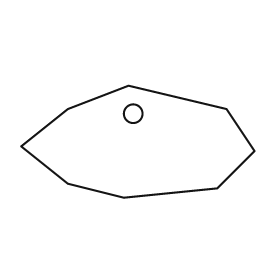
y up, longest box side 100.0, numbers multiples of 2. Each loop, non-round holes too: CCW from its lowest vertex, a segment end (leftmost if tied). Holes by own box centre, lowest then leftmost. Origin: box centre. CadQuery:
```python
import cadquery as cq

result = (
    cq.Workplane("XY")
    .moveTo(-6.0, -24.0)
    .lineTo(34.0, -20.0)
    .lineTo(50.0, -4.0)
    .lineTo(38.0, 14.0)
    .lineTo(-4.0, 24.0)
    .lineTo(-30.0, 14.0)
    .lineTo(-50.0, -2.0)
    .lineTo(-30.0, -18.0)
    .close()
    .moveTo(-2.0, 12.0)
    .circle(4.0)
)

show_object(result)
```